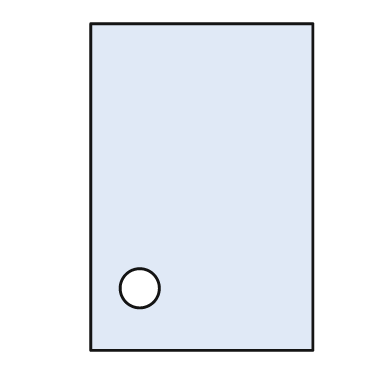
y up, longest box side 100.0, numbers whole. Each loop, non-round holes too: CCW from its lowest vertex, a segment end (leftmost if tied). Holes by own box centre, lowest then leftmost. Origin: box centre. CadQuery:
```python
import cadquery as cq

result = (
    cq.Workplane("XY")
    .moveTo(-34.0, -50.0)
    .lineTo(34.0, -50.0)
    .lineTo(34.0, 50.0)
    .lineTo(-34.0, 50.0)
    .close()
    .moveTo(-19.0, -31.0)
    .circle(6.0)
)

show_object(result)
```